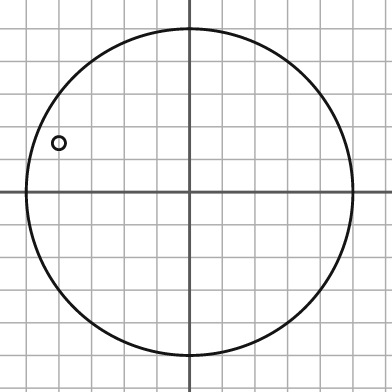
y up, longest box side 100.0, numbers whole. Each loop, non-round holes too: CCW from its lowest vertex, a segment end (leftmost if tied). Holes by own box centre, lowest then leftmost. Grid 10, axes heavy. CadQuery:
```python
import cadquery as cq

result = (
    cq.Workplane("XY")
    .moveTo(0.0, 0.0)
    .circle(50.0)
    .moveTo(-40.0, 15.0)
    .circle(2.0)
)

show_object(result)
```